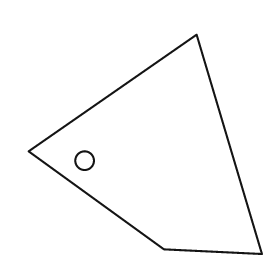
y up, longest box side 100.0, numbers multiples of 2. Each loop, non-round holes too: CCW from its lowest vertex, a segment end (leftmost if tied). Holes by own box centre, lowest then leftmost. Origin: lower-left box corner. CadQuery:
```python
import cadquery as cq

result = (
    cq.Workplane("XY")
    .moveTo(100.0, 0.0)
    .lineTo(72.0, 94.0)
    .lineTo(0.0, 44.0)
    .lineTo(58.0, 2.0)
    .close()
    .moveTo(24.0, 40.0)
    .circle(4.0)
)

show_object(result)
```